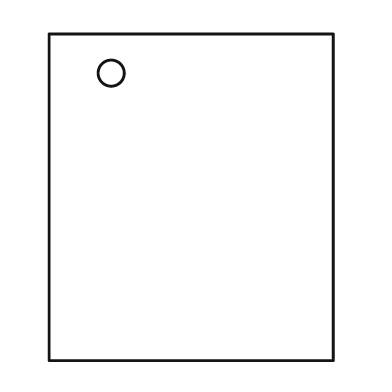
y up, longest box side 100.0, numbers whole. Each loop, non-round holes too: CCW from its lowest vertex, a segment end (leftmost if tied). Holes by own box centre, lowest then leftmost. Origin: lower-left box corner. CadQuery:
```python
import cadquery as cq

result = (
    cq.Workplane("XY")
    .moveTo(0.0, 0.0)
    .lineTo(87.0, 0.0)
    .lineTo(87.0, 100.0)
    .lineTo(0.0, 100.0)
    .close()
    .moveTo(19.0, 88.0)
    .circle(4.0)
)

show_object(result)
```